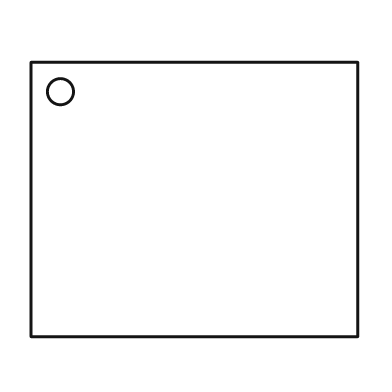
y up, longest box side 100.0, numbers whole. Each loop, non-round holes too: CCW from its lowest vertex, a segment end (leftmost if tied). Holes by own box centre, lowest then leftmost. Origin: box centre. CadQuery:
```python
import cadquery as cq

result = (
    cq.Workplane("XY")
    .moveTo(-50.0, -42.0)
    .lineTo(50.0, -42.0)
    .lineTo(50.0, 42.0)
    .lineTo(-50.0, 42.0)
    .close()
    .moveTo(-41.0, 33.0)
    .circle(4.0)
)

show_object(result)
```